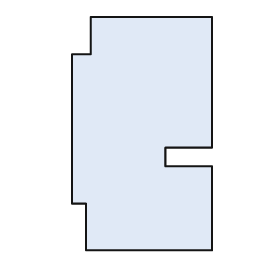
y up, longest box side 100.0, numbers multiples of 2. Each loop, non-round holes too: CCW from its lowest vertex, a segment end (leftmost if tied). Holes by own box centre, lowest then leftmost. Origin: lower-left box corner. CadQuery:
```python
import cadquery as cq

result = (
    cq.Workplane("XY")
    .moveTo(6.0, 0.0)
    .lineTo(60.0, 0.0)
    .lineTo(60.0, 36.0)
    .lineTo(40.0, 36.0)
    .lineTo(40.0, 44.0)
    .lineTo(60.0, 44.0)
    .lineTo(60.0, 100.0)
    .lineTo(8.0, 100.0)
    .lineTo(8.0, 84.0)
    .lineTo(0.0, 84.0)
    .lineTo(0.0, 20.0)
    .lineTo(6.0, 20.0)
    .close()
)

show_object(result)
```